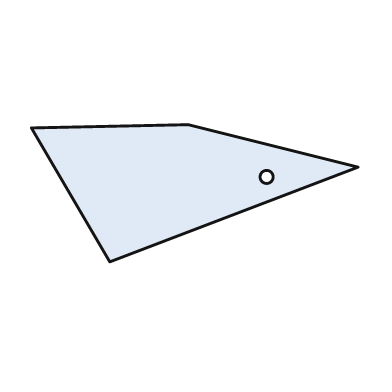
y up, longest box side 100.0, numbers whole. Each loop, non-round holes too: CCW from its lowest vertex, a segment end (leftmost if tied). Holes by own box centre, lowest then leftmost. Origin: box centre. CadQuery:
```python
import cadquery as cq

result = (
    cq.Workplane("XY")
    .moveTo(-26.0, -21.0)
    .lineTo(50.0, 8.0)
    .lineTo(-2.0, 21.0)
    .lineTo(-50.0, 20.0)
    .close()
    .moveTo(22.0, 5.0)
    .circle(2.0)
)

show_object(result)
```